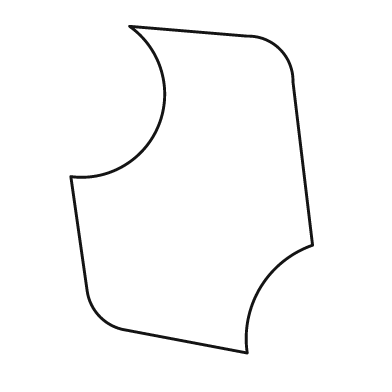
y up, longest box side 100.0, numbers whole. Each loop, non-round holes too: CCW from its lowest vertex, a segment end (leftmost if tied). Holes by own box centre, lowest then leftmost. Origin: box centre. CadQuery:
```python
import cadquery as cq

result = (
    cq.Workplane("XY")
    .moveTo(17.0, -50.0)
    .threePointArc((21.0, -30.0), (37.0, -17.0))
    .lineTo(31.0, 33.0)
    .threePointArc((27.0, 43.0), (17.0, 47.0))
    .lineTo(-19.0, 50.0)
    .threePointArc((-10.0, 20.0), (-37.0, 4.0))
    .lineTo(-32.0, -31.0)
    .threePointArc((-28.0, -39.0), (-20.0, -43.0))
    .close()
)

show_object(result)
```